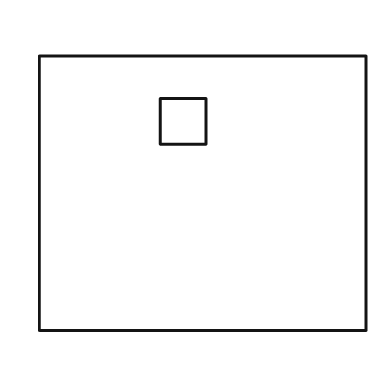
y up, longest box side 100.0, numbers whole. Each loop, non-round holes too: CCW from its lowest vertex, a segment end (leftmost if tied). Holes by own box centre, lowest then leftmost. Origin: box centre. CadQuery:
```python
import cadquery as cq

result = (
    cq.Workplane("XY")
    .moveTo(-50.0, -42.0)
    .lineTo(50.0, -42.0)
    .lineTo(50.0, 42.0)
    .lineTo(-50.0, 42.0)
    .close()
    .moveTo(-13.0, 15.0)
    .lineTo(1.0, 15.0)
    .lineTo(1.0, 29.0)
    .lineTo(-13.0, 29.0)
    .close()
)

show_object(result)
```